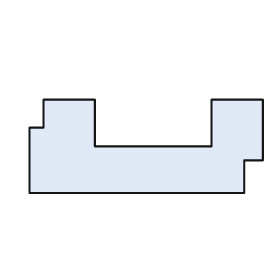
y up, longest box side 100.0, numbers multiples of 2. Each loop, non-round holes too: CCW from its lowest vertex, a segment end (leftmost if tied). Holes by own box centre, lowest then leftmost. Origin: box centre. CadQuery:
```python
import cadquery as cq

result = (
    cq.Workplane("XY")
    .moveTo(-50.0, -20.0)
    .lineTo(42.0, -20.0)
    .lineTo(42.0, -6.0)
    .lineTo(50.0, -6.0)
    .lineTo(50.0, 20.0)
    .lineTo(28.0, 20.0)
    .lineTo(28.0, 0.0)
    .lineTo(-22.0, 0.0)
    .lineTo(-22.0, 20.0)
    .lineTo(-44.0, 20.0)
    .lineTo(-44.0, 8.0)
    .lineTo(-50.0, 8.0)
    .close()
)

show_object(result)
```